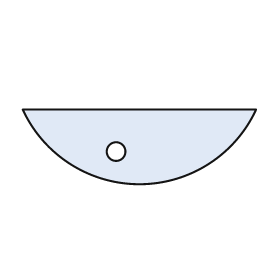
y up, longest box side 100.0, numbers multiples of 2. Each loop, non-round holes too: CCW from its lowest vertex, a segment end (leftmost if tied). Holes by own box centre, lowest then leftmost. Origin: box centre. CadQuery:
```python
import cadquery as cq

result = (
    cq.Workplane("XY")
    .moveTo(-50.0, 16.0)
    .threePointArc((0.0, -16.0), (50.0, 16.0))
    .close()
    .moveTo(-10.0, -2.0)
    .circle(4.0)
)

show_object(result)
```